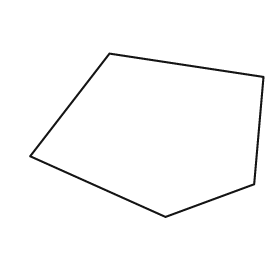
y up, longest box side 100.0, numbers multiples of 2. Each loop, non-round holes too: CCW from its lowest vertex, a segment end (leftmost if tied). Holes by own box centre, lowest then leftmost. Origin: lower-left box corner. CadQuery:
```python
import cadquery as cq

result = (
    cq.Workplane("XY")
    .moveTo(58.0, 0.0)
    .lineTo(96.0, 14.0)
    .lineTo(100.0, 60.0)
    .lineTo(34.0, 70.0)
    .lineTo(0.0, 26.0)
    .close()
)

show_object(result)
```